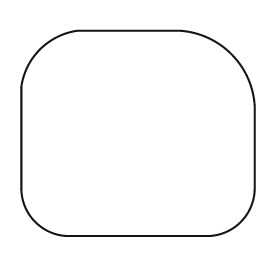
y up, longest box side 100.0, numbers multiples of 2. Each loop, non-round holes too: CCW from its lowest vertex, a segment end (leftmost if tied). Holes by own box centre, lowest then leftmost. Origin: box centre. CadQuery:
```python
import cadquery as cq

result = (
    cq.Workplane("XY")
    .moveTo(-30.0, -44.0)
    .lineTo(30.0, -44.0)
    .threePointArc((44.0, -38.0), (50.0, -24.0))
    .lineTo(50.0, 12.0)
    .threePointArc((40.0, 34.0), (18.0, 44.0))
    .lineTo(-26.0, 44.0)
    .threePointArc((-42.0, 36.0), (-50.0, 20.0))
    .lineTo(-50.0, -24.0)
    .threePointArc((-44.0, -38.0), (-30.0, -44.0))
    .close()
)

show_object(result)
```